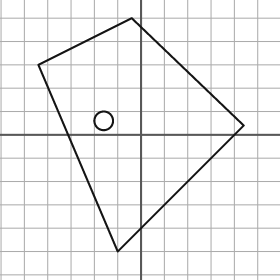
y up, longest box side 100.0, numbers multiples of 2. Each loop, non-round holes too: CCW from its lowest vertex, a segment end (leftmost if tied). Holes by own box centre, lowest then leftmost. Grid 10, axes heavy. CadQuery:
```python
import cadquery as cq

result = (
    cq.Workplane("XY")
    .moveTo(-10.0, -50.0)
    .lineTo(44.0, 4.0)
    .lineTo(-4.0, 50.0)
    .lineTo(-44.0, 30.0)
    .close()
    .moveTo(-16.0, 6.0)
    .circle(4.0)
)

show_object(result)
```